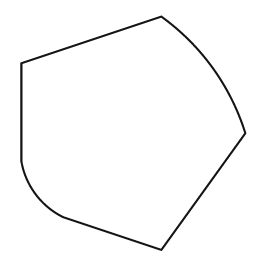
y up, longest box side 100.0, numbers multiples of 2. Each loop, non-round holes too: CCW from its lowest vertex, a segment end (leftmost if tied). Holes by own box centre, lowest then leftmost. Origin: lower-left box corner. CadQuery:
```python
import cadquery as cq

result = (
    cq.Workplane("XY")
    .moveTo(60.0, 0.0)
    .lineTo(96.0, 50.0)
    .threePointArc((82.0, 78.0), (60.0, 100.0))
    .lineTo(0.0, 80.0)
    .lineTo(0.0, 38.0)
    .threePointArc((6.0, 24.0), (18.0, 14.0))
    .close()
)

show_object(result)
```